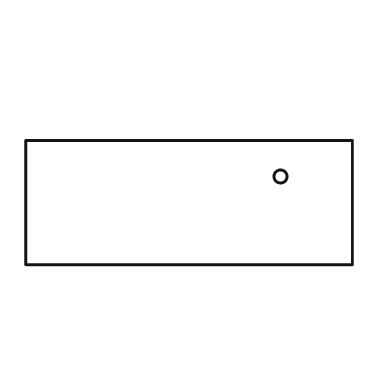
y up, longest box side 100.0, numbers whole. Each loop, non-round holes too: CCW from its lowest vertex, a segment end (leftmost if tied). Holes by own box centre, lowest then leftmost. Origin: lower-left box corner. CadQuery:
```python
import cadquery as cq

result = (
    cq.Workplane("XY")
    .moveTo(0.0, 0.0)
    .lineTo(100.0, 0.0)
    .lineTo(100.0, 38.0)
    .lineTo(0.0, 38.0)
    .close()
    .moveTo(78.0, 27.0)
    .circle(2.0)
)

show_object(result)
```